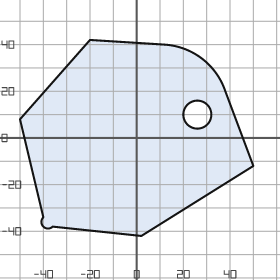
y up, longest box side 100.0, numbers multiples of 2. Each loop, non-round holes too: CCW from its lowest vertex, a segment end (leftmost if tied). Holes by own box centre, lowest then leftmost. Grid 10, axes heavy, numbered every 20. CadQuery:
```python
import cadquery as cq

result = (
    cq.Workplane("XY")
    .moveTo(2.0, -42.0)
    .lineTo(50.0, -12.0)
    .lineTo(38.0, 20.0)
    .threePointArc((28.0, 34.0), (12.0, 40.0))
    .lineTo(-20.0, 42.0)
    .lineTo(-50.0, 8.0)
    .lineTo(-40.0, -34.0)
    .threePointArc((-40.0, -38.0), (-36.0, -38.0))
    .close()
    .moveTo(26.0, 10.0)
    .circle(6.0)
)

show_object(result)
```